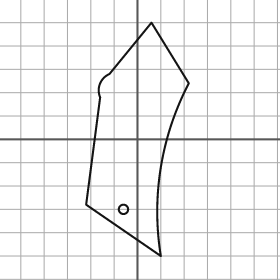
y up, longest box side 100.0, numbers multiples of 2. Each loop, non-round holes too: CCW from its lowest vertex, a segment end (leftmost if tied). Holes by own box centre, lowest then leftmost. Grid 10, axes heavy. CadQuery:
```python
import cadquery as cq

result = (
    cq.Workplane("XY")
    .moveTo(10.0, -50.0)
    .threePointArc((10.0, -12.0), (22.0, 24.0))
    .lineTo(6.0, 50.0)
    .lineTo(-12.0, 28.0)
    .threePointArc((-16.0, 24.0), (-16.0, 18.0))
    .lineTo(-22.0, -28.0)
    .close()
    .moveTo(-6.0, -30.0)
    .circle(2.0)
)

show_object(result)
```